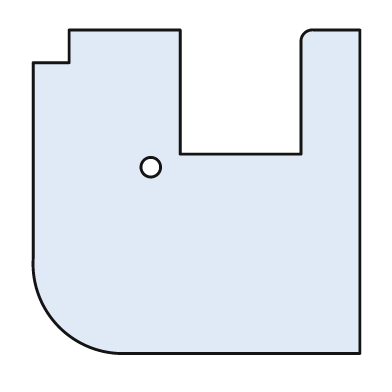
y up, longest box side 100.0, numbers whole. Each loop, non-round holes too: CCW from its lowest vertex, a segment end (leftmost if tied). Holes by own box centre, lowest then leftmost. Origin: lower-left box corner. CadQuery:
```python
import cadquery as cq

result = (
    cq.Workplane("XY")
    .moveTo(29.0, 0.0)
    .lineTo(100.0, 0.0)
    .lineTo(100.0, 99.0)
    .lineTo(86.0, 99.0)
    .threePointArc((83.0, 98.0), (82.0, 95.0))
    .lineTo(82.0, 61.0)
    .lineTo(45.0, 61.0)
    .lineTo(45.0, 99.0)
    .lineTo(11.0, 99.0)
    .lineTo(11.0, 89.0)
    .lineTo(0.0, 89.0)
    .lineTo(0.0, 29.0)
    .threePointArc((8.0, 8.0), (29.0, 0.0))
    .close()
    .moveTo(36.0, 57.0)
    .circle(3.0)
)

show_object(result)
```